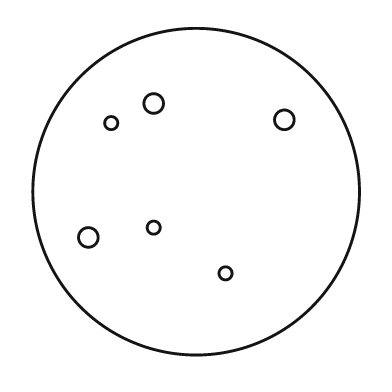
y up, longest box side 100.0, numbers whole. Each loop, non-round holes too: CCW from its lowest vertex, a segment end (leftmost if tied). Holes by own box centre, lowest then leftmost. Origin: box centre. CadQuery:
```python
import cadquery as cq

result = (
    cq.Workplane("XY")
    .moveTo(0.0, 0.0)
    .circle(50.0)
    .moveTo(9.0, -25.0)
    .circle(2.0)
    .moveTo(-33.0, -14.0)
    .circle(3.0)
    .moveTo(-13.0, -11.0)
    .circle(2.0)
    .moveTo(-26.0, 21.0)
    .circle(2.0)
    .moveTo(27.0, 22.0)
    .circle(3.0)
    .moveTo(-13.0, 27.0)
    .circle(3.0)
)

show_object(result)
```